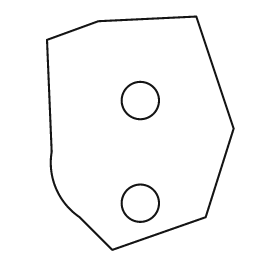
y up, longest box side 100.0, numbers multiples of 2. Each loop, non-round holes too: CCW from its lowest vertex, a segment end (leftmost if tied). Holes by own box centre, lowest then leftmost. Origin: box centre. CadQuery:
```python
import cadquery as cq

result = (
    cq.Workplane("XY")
    .moveTo(-12.0, -50.0)
    .lineTo(28.0, -36.0)
    .lineTo(40.0, 2.0)
    .lineTo(24.0, 50.0)
    .lineTo(-18.0, 48.0)
    .lineTo(-40.0, 40.0)
    .lineTo(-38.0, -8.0)
    .threePointArc((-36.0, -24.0), (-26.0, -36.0))
    .close()
    .moveTo(0.0, -30.0)
    .circle(8.0)
    .moveTo(0.0, 14.0)
    .circle(8.0)
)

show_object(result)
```